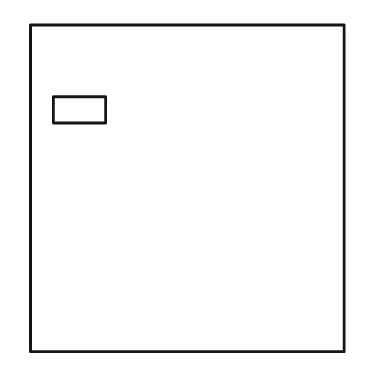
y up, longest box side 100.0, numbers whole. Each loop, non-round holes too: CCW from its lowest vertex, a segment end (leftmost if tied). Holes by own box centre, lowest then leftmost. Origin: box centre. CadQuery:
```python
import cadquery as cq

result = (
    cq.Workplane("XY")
    .moveTo(-48.0, -50.0)
    .lineTo(48.0, -50.0)
    .lineTo(48.0, 50.0)
    .lineTo(-48.0, 50.0)
    .close()
    .moveTo(-41.0, 20.0)
    .lineTo(-25.0, 20.0)
    .lineTo(-25.0, 28.0)
    .lineTo(-41.0, 28.0)
    .close()
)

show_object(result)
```